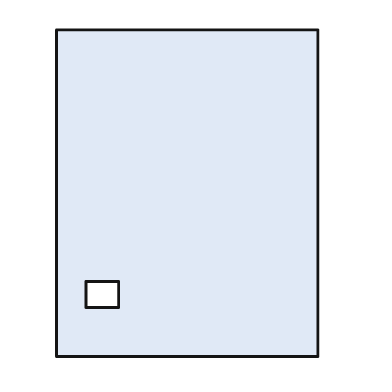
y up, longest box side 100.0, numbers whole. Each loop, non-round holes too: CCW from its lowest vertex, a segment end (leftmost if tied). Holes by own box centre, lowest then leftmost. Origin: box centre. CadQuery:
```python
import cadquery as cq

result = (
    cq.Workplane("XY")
    .moveTo(-40.0, -50.0)
    .lineTo(40.0, -50.0)
    .lineTo(40.0, 50.0)
    .lineTo(-40.0, 50.0)
    .close()
    .moveTo(-31.0, -35.0)
    .lineTo(-21.0, -35.0)
    .lineTo(-21.0, -27.0)
    .lineTo(-31.0, -27.0)
    .close()
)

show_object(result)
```